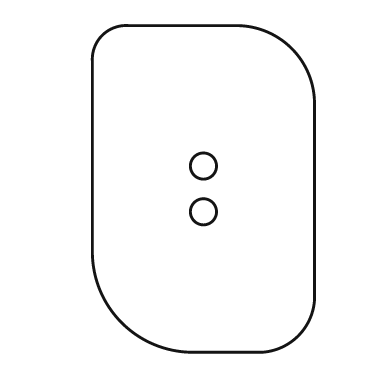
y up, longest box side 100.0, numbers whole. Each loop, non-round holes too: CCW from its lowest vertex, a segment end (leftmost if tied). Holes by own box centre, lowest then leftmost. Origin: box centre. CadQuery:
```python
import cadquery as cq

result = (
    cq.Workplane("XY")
    .moveTo(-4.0, -50.0)
    .lineTo(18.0, -50.0)
    .threePointArc((29.0, -45.0), (34.0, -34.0))
    .lineTo(34.0, 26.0)
    .threePointArc((27.0, 43.0), (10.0, 50.0))
    .lineTo(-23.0, 50.0)
    .threePointArc((-31.0, 47.0), (-34.0, 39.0))
    .lineTo(-34.0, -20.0)
    .threePointArc((-25.0, -41.0), (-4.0, -50.0))
    .close()
    .moveTo(0.0, -7.0)
    .circle(4.0)
    .moveTo(0.0, 7.0)
    .circle(4.0)
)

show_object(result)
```